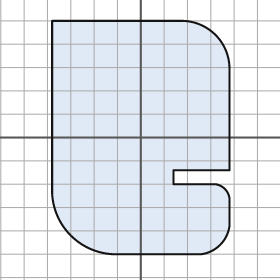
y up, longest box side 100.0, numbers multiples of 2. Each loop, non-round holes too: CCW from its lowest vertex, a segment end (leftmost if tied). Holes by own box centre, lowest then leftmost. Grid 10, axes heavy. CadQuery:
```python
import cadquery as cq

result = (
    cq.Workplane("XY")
    .moveTo(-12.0, -50.0)
    .lineTo(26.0, -50.0)
    .threePointArc((34.0, -46.0), (38.0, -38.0))
    .lineTo(38.0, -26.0)
    .threePointArc((36.0, -22.0), (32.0, -20.0))
    .lineTo(14.0, -20.0)
    .lineTo(14.0, -14.0)
    .lineTo(38.0, -14.0)
    .lineTo(38.0, 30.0)
    .threePointArc((32.0, 44.0), (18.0, 50.0))
    .lineTo(-38.0, 50.0)
    .lineTo(-38.0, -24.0)
    .threePointArc((-30.0, -42.0), (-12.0, -50.0))
    .close()
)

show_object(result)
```